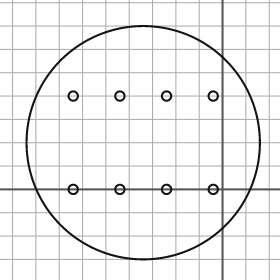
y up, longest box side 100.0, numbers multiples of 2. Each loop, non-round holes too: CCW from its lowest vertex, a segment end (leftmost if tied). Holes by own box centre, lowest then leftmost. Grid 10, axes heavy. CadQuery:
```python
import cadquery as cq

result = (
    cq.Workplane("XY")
    .moveTo(-34.0, 20.0)
    .circle(50.0)
    .moveTo(-64.0, 0.0)
    .circle(2.0)
    .moveTo(-44.0, 0.0)
    .circle(2.0)
    .moveTo(-24.0, 0.0)
    .circle(2.0)
    .moveTo(-4.0, 0.0)
    .circle(2.0)
    .moveTo(-64.0, 40.0)
    .circle(2.0)
    .moveTo(-44.0, 40.0)
    .circle(2.0)
    .moveTo(-24.0, 40.0)
    .circle(2.0)
    .moveTo(-4.0, 40.0)
    .circle(2.0)
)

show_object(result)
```